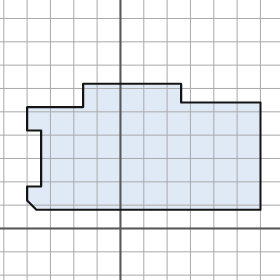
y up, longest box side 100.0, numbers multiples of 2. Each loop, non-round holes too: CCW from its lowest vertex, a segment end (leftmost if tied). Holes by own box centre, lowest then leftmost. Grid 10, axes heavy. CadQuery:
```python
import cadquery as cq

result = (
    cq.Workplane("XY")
    .moveTo(-36.0, 8.0)
    .lineTo(60.0, 8.0)
    .lineTo(60.0, 54.0)
    .lineTo(26.0, 54.0)
    .lineTo(26.0, 62.0)
    .lineTo(-16.0, 62.0)
    .lineTo(-16.0, 52.0)
    .lineTo(-40.0, 52.0)
    .lineTo(-40.0, 42.0)
    .lineTo(-34.0, 42.0)
    .lineTo(-34.0, 18.0)
    .lineTo(-40.0, 18.0)
    .lineTo(-40.0, 12.0)
    .close()
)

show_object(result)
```